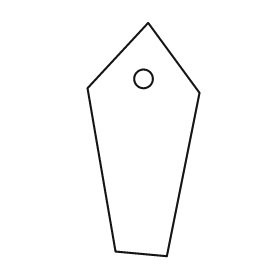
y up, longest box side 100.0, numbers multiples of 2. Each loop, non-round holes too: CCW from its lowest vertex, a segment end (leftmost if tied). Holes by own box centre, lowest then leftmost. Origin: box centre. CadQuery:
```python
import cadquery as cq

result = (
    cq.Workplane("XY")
    .moveTo(10.0, -50.0)
    .lineTo(24.0, 20.0)
    .lineTo(2.0, 50.0)
    .lineTo(-24.0, 22.0)
    .lineTo(-12.0, -48.0)
    .close()
    .moveTo(0.0, 26.0)
    .circle(4.0)
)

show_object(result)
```